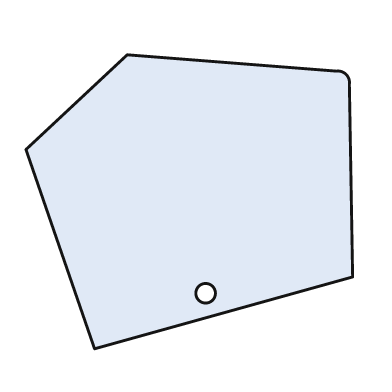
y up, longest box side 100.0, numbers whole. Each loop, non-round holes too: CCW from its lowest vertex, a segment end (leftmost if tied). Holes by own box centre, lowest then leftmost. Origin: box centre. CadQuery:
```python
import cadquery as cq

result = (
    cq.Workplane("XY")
    .moveTo(-29.0, -45.0)
    .lineTo(50.0, -23.0)
    .lineTo(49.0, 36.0)
    .threePointArc((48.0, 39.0), (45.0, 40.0))
    .lineTo(-19.0, 45.0)
    .lineTo(-50.0, 16.0)
    .close()
    .moveTo(5.0, -28.0)
    .circle(3.0)
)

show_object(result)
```